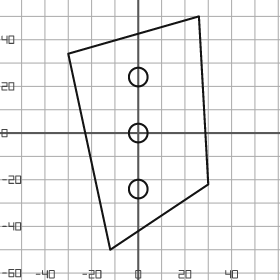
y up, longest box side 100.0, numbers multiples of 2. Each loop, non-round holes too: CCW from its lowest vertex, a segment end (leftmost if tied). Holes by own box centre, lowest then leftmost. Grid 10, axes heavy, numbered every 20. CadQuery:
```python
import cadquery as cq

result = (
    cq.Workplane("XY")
    .moveTo(-12.0, -50.0)
    .lineTo(30.0, -22.0)
    .lineTo(26.0, 50.0)
    .lineTo(-30.0, 34.0)
    .close()
    .moveTo(0.0, -24.0)
    .circle(4.0)
    .moveTo(0.0, 0.0)
    .circle(4.0)
    .moveTo(0.0, 24.0)
    .circle(4.0)
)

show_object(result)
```